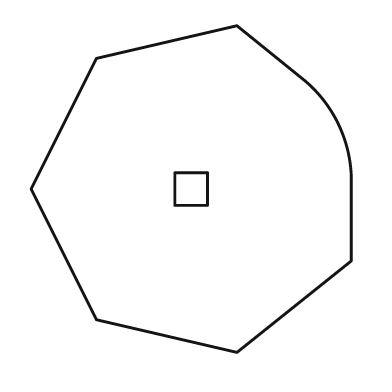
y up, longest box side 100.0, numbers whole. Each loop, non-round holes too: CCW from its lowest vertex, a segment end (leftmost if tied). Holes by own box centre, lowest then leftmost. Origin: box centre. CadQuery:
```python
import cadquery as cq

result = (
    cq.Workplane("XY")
    .moveTo(14.0, -50.0)
    .lineTo(49.0, -22.0)
    .lineTo(49.0, 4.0)
    .threePointArc((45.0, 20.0), (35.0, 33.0))
    .lineTo(14.0, 50.0)
    .lineTo(-29.0, 40.0)
    .lineTo(-49.0, 0.0)
    .lineTo(-29.0, -40.0)
    .close()
    .moveTo(-5.0, -5.0)
    .lineTo(5.0, -5.0)
    .lineTo(5.0, 5.0)
    .lineTo(-5.0, 5.0)
    .close()
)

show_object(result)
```